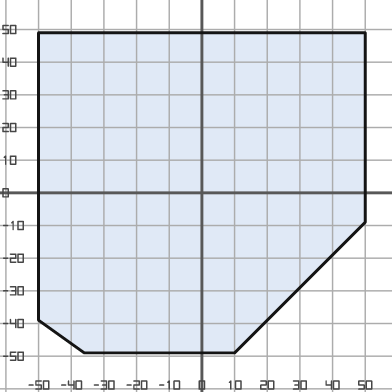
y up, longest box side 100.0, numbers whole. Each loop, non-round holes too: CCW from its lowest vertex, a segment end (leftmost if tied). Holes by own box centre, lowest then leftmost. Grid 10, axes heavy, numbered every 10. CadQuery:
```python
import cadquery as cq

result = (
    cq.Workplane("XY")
    .moveTo(-36.0, -49.0)
    .lineTo(10.0, -49.0)
    .lineTo(50.0, -9.0)
    .lineTo(50.0, 49.0)
    .lineTo(-50.0, 49.0)
    .lineTo(-50.0, -39.0)
    .close()
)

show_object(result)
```